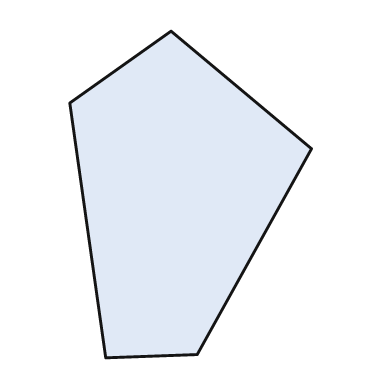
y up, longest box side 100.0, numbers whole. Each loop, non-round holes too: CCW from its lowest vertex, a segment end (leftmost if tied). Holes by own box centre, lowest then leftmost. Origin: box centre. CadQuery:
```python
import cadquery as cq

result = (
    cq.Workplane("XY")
    .moveTo(-26.0, -50.0)
    .lineTo(2.0, -49.0)
    .lineTo(37.0, 14.0)
    .lineTo(-6.0, 50.0)
    .lineTo(-37.0, 28.0)
    .close()
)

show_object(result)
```